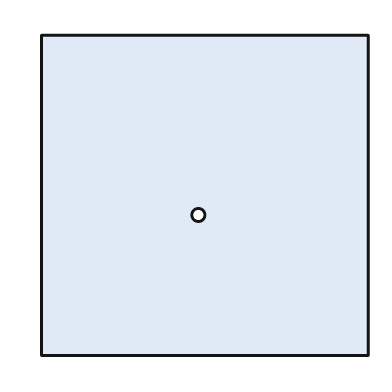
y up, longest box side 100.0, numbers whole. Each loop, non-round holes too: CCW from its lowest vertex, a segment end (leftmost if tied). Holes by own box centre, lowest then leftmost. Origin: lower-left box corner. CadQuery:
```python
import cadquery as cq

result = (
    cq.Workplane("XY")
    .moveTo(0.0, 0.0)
    .lineTo(100.0, 0.0)
    .lineTo(100.0, 98.0)
    .lineTo(0.0, 98.0)
    .close()
    .moveTo(48.0, 43.0)
    .circle(2.0)
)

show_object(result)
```